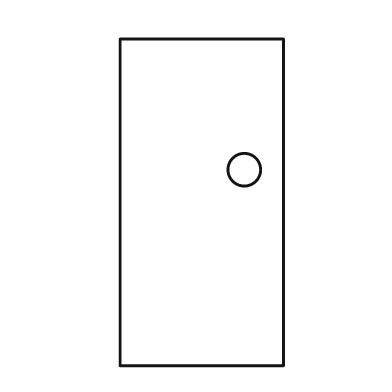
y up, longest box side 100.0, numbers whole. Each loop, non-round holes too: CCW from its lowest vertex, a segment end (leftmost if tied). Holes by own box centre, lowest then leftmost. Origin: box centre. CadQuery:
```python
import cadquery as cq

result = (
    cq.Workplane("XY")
    .moveTo(-25.0, -50.0)
    .lineTo(25.0, -50.0)
    .lineTo(25.0, 50.0)
    .lineTo(-25.0, 50.0)
    .close()
    .moveTo(13.0, 10.0)
    .circle(5.0)
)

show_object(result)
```